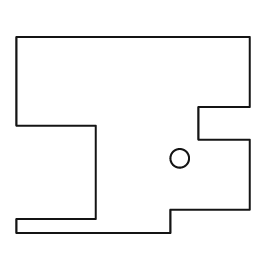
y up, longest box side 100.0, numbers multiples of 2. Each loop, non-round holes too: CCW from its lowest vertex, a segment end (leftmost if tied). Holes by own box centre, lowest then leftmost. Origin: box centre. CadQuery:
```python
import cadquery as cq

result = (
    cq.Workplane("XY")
    .moveTo(-50.0, -42.0)
    .lineTo(16.0, -42.0)
    .lineTo(16.0, -32.0)
    .lineTo(50.0, -32.0)
    .lineTo(50.0, -2.0)
    .lineTo(28.0, -2.0)
    .lineTo(28.0, 12.0)
    .lineTo(50.0, 12.0)
    .lineTo(50.0, 42.0)
    .lineTo(-50.0, 42.0)
    .lineTo(-50.0, 4.0)
    .lineTo(-16.0, 4.0)
    .lineTo(-16.0, -36.0)
    .lineTo(-50.0, -36.0)
    .close()
    .moveTo(20.0, -10.0)
    .circle(4.0)
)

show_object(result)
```